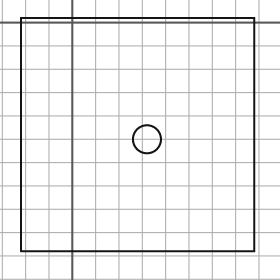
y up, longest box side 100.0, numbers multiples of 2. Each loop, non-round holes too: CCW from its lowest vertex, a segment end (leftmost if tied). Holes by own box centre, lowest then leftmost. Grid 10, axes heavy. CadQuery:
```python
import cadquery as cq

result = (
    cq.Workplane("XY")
    .moveTo(-22.0, -98.0)
    .lineTo(78.0, -98.0)
    .lineTo(78.0, 2.0)
    .lineTo(-22.0, 2.0)
    .close()
    .moveTo(32.0, -50.0)
    .circle(6.0)
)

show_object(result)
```